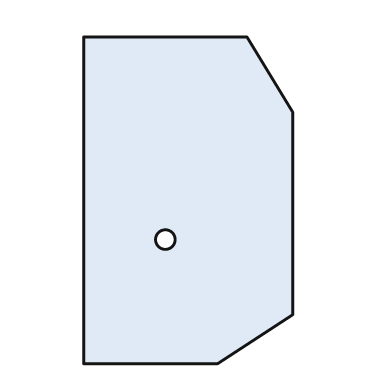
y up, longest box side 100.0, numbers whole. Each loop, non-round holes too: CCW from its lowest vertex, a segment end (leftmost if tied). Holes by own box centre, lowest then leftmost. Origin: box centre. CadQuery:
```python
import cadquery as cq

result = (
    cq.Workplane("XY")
    .moveTo(-32.0, -50.0)
    .lineTo(9.0, -50.0)
    .lineTo(32.0, -35.0)
    .lineTo(32.0, 27.0)
    .lineTo(18.0, 50.0)
    .lineTo(-32.0, 50.0)
    .close()
    .moveTo(-7.0, -12.0)
    .circle(3.0)
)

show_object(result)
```